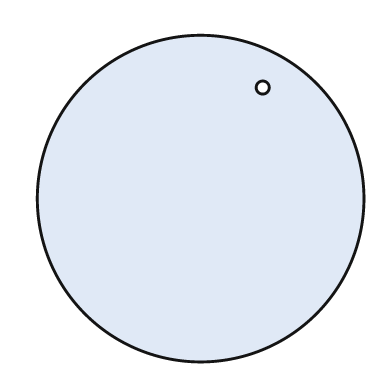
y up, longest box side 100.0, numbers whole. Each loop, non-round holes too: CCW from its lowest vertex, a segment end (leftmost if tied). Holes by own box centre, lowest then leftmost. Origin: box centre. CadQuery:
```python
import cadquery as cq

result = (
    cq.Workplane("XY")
    .moveTo(0.0, 0.0)
    .circle(50.0)
    .moveTo(19.0, 34.0)
    .circle(2.0)
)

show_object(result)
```